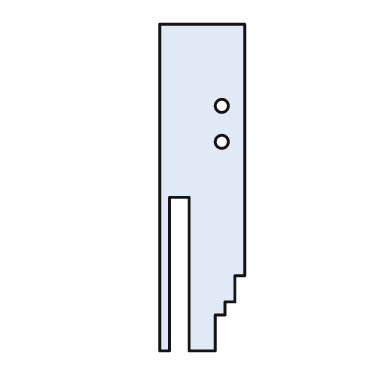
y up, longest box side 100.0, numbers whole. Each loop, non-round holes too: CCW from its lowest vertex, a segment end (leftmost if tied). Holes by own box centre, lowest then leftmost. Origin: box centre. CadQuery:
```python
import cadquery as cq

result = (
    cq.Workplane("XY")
    .moveTo(-13.0, -50.0)
    .lineTo(-10.0, -50.0)
    .lineTo(-10.0, -3.0)
    .lineTo(-4.0, -3.0)
    .lineTo(-4.0, -50.0)
    .lineTo(4.0, -50.0)
    .lineTo(4.0, -39.0)
    .lineTo(7.0, -39.0)
    .lineTo(7.0, -35.0)
    .lineTo(10.0, -35.0)
    .lineTo(10.0, -27.0)
    .lineTo(13.0, -27.0)
    .lineTo(13.0, 50.0)
    .lineTo(-13.0, 50.0)
    .close()
    .moveTo(6.0, 14.0)
    .circle(2.0)
    .moveTo(6.0, 25.0)
    .circle(2.0)
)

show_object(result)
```